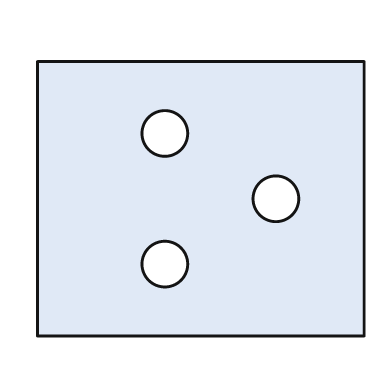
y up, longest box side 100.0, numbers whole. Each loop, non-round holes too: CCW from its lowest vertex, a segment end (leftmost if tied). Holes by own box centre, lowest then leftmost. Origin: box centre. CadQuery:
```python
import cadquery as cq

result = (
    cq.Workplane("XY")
    .moveTo(-50.0, -42.0)
    .lineTo(50.0, -42.0)
    .lineTo(50.0, 42.0)
    .lineTo(-50.0, 42.0)
    .close()
    .moveTo(-11.0, -20.0)
    .circle(7.0)
    .moveTo(23.0, 0.0)
    .circle(7.0)
    .moveTo(-11.0, 20.0)
    .circle(7.0)
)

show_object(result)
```